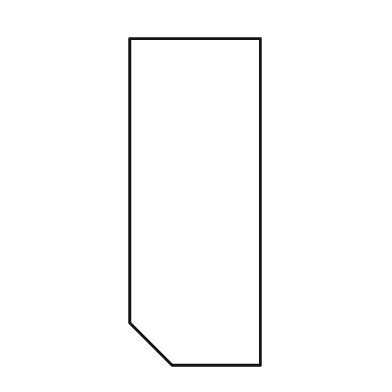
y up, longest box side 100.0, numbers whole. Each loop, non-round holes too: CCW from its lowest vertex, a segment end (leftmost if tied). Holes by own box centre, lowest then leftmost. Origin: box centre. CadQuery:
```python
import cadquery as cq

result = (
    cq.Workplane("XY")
    .moveTo(-7.0, -50.0)
    .lineTo(20.0, -50.0)
    .lineTo(20.0, 50.0)
    .lineTo(-20.0, 50.0)
    .lineTo(-20.0, -37.0)
    .close()
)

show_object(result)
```